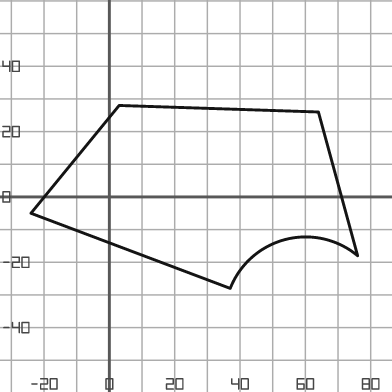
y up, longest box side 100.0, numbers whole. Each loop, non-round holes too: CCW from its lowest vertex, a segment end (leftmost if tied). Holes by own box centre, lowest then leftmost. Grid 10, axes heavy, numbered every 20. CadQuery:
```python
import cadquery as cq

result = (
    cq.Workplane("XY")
    .moveTo(37.0, -28.0)
    .threePointArc((54.0, -13.0), (76.0, -18.0))
    .lineTo(64.0, 26.0)
    .lineTo(3.0, 28.0)
    .lineTo(-24.0, -5.0)
    .close()
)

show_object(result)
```